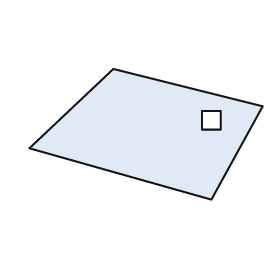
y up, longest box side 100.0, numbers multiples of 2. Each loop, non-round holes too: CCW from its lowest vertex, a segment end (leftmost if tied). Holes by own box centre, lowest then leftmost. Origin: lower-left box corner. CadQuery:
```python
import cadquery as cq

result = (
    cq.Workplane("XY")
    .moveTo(78.0, 0.0)
    .lineTo(100.0, 40.0)
    .lineTo(36.0, 56.0)
    .lineTo(0.0, 22.0)
    .close()
    .moveTo(74.0, 30.0)
    .lineTo(82.0, 30.0)
    .lineTo(82.0, 38.0)
    .lineTo(74.0, 38.0)
    .close()
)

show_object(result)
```